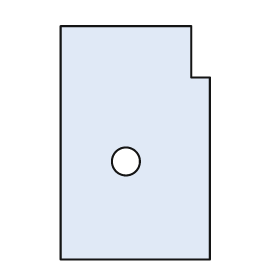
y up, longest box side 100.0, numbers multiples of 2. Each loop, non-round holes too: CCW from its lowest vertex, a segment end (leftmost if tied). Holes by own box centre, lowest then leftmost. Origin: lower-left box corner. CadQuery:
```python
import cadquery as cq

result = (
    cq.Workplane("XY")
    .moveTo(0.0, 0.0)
    .lineTo(64.0, 0.0)
    .lineTo(64.0, 78.0)
    .lineTo(56.0, 78.0)
    .lineTo(56.0, 100.0)
    .lineTo(0.0, 100.0)
    .close()
    .moveTo(28.0, 42.0)
    .circle(6.0)
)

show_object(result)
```